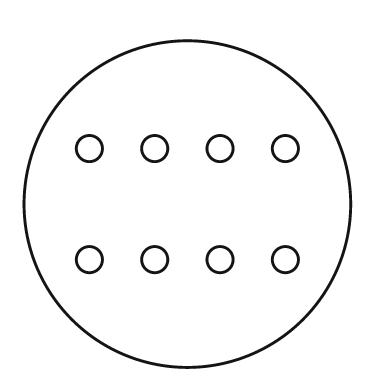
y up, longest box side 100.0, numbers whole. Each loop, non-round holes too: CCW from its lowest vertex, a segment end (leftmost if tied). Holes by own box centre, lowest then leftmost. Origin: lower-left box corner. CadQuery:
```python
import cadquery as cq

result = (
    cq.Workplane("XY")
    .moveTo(50.0, 50.0)
    .circle(50.0)
    .moveTo(20.0, 33.0)
    .circle(4.0)
    .moveTo(40.0, 33.0)
    .circle(4.0)
    .moveTo(60.0, 33.0)
    .circle(4.0)
    .moveTo(80.0, 33.0)
    .circle(4.0)
    .moveTo(20.0, 67.0)
    .circle(4.0)
    .moveTo(40.0, 67.0)
    .circle(4.0)
    .moveTo(60.0, 67.0)
    .circle(4.0)
    .moveTo(80.0, 67.0)
    .circle(4.0)
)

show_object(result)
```